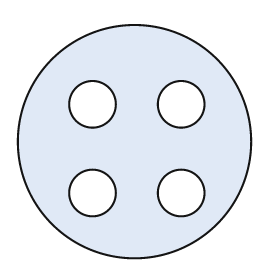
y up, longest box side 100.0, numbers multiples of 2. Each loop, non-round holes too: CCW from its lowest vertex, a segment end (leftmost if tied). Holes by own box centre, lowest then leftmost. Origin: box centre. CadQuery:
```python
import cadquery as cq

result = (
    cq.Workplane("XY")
    .moveTo(0.0, 0.0)
    .circle(50.0)
    .moveTo(-18.0, -22.0)
    .circle(10.0)
    .moveTo(20.0, -22.0)
    .circle(10.0)
    .moveTo(-18.0, 16.0)
    .circle(10.0)
    .moveTo(20.0, 16.0)
    .circle(10.0)
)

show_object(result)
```